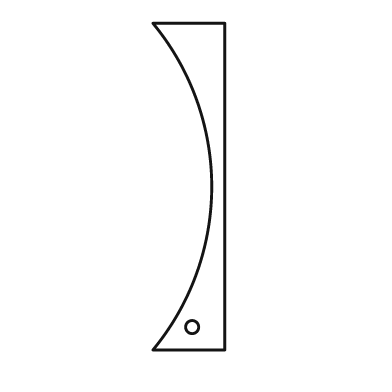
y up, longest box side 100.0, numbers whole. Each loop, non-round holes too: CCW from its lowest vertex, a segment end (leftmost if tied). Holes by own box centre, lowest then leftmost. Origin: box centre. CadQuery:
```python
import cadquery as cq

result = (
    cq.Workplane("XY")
    .moveTo(-11.0, -50.0)
    .lineTo(11.0, -50.0)
    .lineTo(11.0, 50.0)
    .lineTo(-11.0, 50.0)
    .threePointArc((7.0, 0.0), (-11.0, -50.0))
    .close()
    .moveTo(1.0, -43.0)
    .circle(2.0)
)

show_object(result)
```